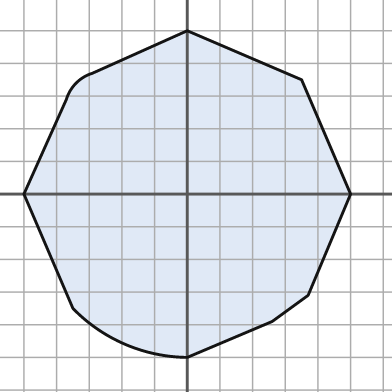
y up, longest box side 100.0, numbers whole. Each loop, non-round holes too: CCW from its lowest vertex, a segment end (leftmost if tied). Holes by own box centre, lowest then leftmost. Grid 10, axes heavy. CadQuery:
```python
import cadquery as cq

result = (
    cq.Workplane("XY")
    .moveTo(0.0, -50.0)
    .lineTo(26.0, -39.0)
    .lineTo(37.0, -31.0)
    .lineTo(50.0, 0.0)
    .lineTo(35.0, 35.0)
    .lineTo(0.0, 50.0)
    .lineTo(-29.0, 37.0)
    .threePointArc((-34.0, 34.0), (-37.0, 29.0))
    .lineTo(-50.0, 0.0)
    .lineTo(-35.0, -35.0)
    .threePointArc((-19.0, -46.0), (0.0, -50.0))
    .close()
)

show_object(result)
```